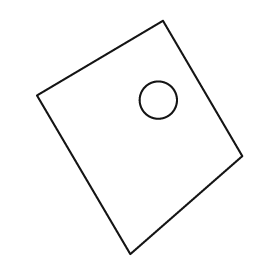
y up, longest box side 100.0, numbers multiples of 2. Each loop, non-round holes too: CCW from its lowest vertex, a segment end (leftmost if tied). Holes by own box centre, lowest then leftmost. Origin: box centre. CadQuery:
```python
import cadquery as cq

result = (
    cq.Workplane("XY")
    .moveTo(-4.0, -50.0)
    .lineTo(44.0, -8.0)
    .lineTo(10.0, 50.0)
    .lineTo(-44.0, 18.0)
    .close()
    .moveTo(8.0, 16.0)
    .circle(8.0)
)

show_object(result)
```